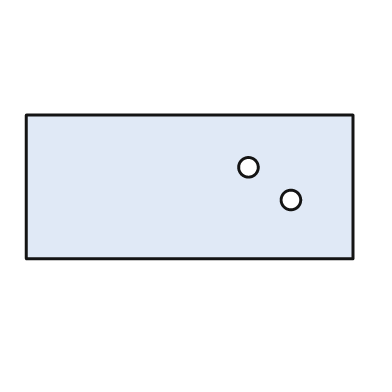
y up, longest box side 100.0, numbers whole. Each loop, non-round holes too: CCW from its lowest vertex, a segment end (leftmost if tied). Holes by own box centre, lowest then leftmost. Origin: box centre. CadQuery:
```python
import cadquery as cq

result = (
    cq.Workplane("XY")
    .moveTo(-50.0, -22.0)
    .lineTo(50.0, -22.0)
    .lineTo(50.0, 22.0)
    .lineTo(-50.0, 22.0)
    .close()
    .moveTo(31.0, -4.0)
    .circle(3.0)
    .moveTo(18.0, 6.0)
    .circle(3.0)
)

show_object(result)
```